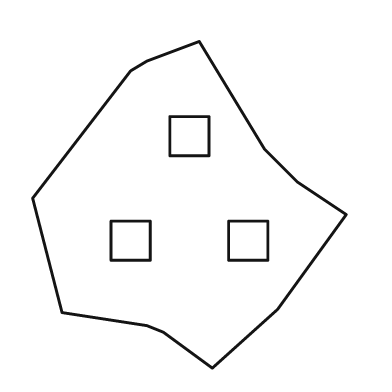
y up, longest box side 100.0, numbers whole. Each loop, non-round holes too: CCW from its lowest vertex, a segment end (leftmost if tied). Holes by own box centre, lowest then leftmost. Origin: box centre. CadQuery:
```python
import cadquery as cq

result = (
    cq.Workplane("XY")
    .moveTo(7.0, -50.0)
    .lineTo(27.0, -32.0)
    .lineTo(48.0, -3.0)
    .lineTo(33.0, 7.0)
    .lineTo(23.0, 17.0)
    .lineTo(3.0, 50.0)
    .lineTo(-13.0, 44.0)
    .lineTo(-18.0, 41.0)
    .lineTo(-48.0, 2.0)
    .lineTo(-39.0, -33.0)
    .lineTo(-13.0, -37.0)
    .lineTo(-8.0, -39.0)
    .close()
    .moveTo(-24.0, -17.0)
    .lineTo(-12.0, -17.0)
    .lineTo(-12.0, -5.0)
    .lineTo(-24.0, -5.0)
    .close()
    .moveTo(12.0, -17.0)
    .lineTo(24.0, -17.0)
    .lineTo(24.0, -5.0)
    .lineTo(12.0, -5.0)
    .close()
    .moveTo(-6.0, 15.0)
    .lineTo(6.0, 15.0)
    .lineTo(6.0, 27.0)
    .lineTo(-6.0, 27.0)
    .close()
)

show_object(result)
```